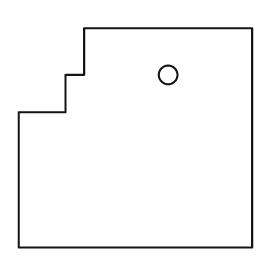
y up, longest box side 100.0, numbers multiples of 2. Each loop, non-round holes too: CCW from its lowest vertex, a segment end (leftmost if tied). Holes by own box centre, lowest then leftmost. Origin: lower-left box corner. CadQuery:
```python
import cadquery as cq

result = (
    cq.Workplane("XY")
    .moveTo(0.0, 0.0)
    .lineTo(100.0, 0.0)
    .lineTo(100.0, 94.0)
    .lineTo(28.0, 94.0)
    .lineTo(28.0, 74.0)
    .lineTo(20.0, 74.0)
    .lineTo(20.0, 58.0)
    .lineTo(0.0, 58.0)
    .close()
    .moveTo(64.0, 74.0)
    .circle(4.0)
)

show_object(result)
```